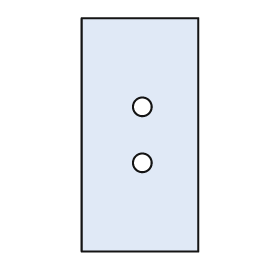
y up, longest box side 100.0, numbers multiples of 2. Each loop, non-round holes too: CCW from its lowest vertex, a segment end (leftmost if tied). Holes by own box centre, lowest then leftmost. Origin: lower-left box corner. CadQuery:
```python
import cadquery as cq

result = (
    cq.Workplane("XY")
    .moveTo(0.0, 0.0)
    .lineTo(50.0, 0.0)
    .lineTo(50.0, 100.0)
    .lineTo(0.0, 100.0)
    .close()
    .moveTo(26.0, 38.0)
    .circle(4.0)
    .moveTo(26.0, 62.0)
    .circle(4.0)
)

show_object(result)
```